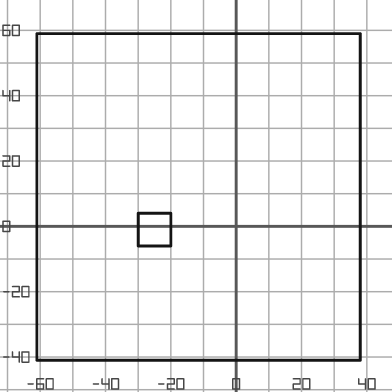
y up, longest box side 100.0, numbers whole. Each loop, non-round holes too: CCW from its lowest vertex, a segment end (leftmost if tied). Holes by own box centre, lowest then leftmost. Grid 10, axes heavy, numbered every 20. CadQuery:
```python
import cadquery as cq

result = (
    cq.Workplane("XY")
    .moveTo(-61.0, -41.0)
    .lineTo(38.0, -41.0)
    .lineTo(38.0, 59.0)
    .lineTo(-61.0, 59.0)
    .close()
    .moveTo(-30.0, -6.0)
    .lineTo(-20.0, -6.0)
    .lineTo(-20.0, 4.0)
    .lineTo(-30.0, 4.0)
    .close()
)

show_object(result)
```